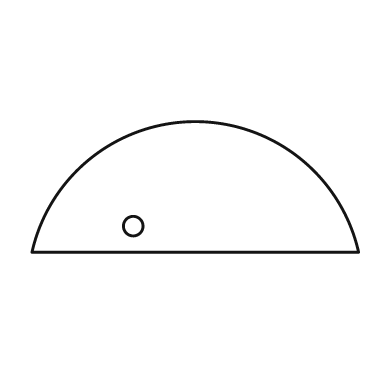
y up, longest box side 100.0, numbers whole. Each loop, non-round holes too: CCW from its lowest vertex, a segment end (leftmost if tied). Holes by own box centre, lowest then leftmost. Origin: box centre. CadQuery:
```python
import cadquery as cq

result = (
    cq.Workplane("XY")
    .moveTo(-50.0, -20.0)
    .lineTo(50.0, -20.0)
    .threePointArc((0.0, 20.0), (-50.0, -20.0))
    .close()
    .moveTo(-19.0, -12.0)
    .circle(3.0)
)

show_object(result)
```